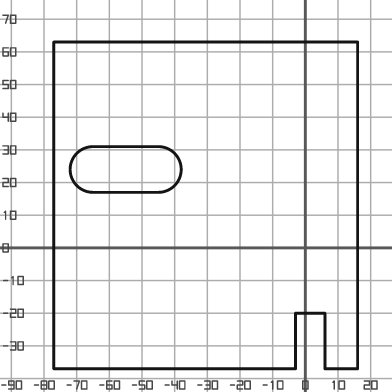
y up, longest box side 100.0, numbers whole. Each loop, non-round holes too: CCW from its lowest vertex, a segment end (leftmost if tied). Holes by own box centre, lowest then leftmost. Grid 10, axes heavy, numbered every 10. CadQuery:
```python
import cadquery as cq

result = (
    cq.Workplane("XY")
    .moveTo(-77.0, -37.0)
    .lineTo(-3.0, -37.0)
    .lineTo(-3.0, -20.0)
    .lineTo(6.0, -20.0)
    .lineTo(6.0, -37.0)
    .lineTo(16.0, -37.0)
    .lineTo(16.0, 63.0)
    .lineTo(-77.0, 63.0)
    .close()
    .moveTo(-65.0, 17.0)
    .lineTo(-45.0, 17.0)
    .threePointArc((-38.0, 24.0), (-45.0, 31.0))
    .lineTo(-65.0, 31.0)
    .threePointArc((-72.0, 24.0), (-65.0, 17.0))
    .close()
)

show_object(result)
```